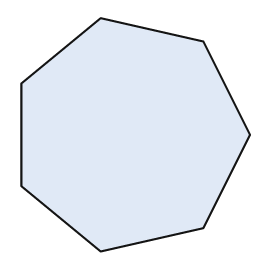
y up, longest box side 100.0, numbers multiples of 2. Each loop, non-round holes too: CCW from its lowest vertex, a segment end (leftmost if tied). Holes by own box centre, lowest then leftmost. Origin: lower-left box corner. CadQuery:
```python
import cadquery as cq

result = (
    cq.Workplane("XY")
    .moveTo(34.0, 0.0)
    .lineTo(78.0, 10.0)
    .lineTo(98.0, 50.0)
    .lineTo(78.0, 90.0)
    .lineTo(34.0, 100.0)
    .lineTo(0.0, 72.0)
    .lineTo(0.0, 28.0)
    .close()
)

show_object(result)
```